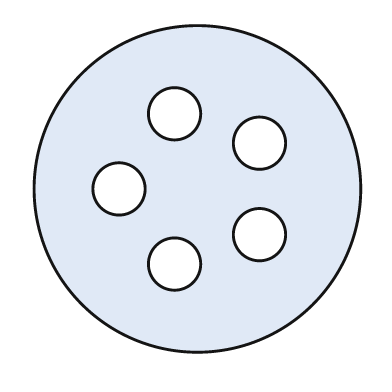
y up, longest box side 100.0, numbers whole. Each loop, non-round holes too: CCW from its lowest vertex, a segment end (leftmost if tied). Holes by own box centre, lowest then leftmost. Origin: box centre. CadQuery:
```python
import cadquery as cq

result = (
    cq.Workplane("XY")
    .moveTo(0.0, 0.0)
    .circle(50.0)
    .moveTo(-7.0, -23.0)
    .circle(8.0)
    .moveTo(19.0, -14.0)
    .circle(8.0)
    .moveTo(-24.0, 0.0)
    .circle(8.0)
    .moveTo(19.0, 14.0)
    .circle(8.0)
    .moveTo(-7.0, 23.0)
    .circle(8.0)
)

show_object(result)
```